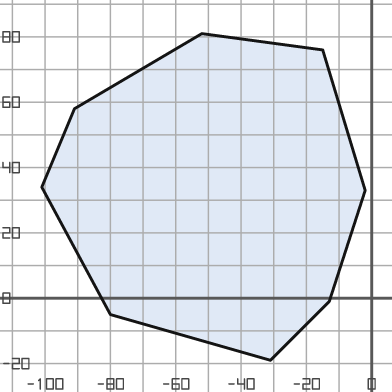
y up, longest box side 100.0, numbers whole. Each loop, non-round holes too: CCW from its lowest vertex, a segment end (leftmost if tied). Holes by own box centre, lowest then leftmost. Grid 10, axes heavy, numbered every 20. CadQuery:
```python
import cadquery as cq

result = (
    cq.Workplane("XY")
    .moveTo(-31.0, -19.0)
    .lineTo(-13.0, -1.0)
    .lineTo(-2.0, 33.0)
    .lineTo(-15.0, 76.0)
    .lineTo(-52.0, 81.0)
    .lineTo(-91.0, 58.0)
    .lineTo(-101.0, 34.0)
    .lineTo(-80.0, -5.0)
    .close()
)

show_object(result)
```